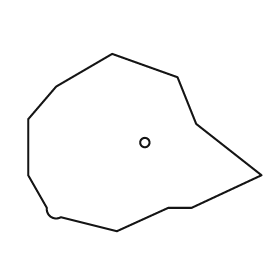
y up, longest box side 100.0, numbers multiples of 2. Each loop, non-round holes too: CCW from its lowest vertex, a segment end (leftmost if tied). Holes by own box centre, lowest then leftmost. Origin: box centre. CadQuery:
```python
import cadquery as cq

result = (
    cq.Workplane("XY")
    .moveTo(-12.0, -38.0)
    .lineTo(10.0, -28.0)
    .lineTo(20.0, -28.0)
    .lineTo(50.0, -14.0)
    .lineTo(22.0, 8.0)
    .lineTo(14.0, 28.0)
    .lineTo(-14.0, 38.0)
    .lineTo(-38.0, 24.0)
    .lineTo(-50.0, 10.0)
    .lineTo(-50.0, -14.0)
    .lineTo(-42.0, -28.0)
    .threePointArc((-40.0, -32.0), (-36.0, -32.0))
    .close()
    .moveTo(0.0, 0.0)
    .circle(2.0)
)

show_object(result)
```